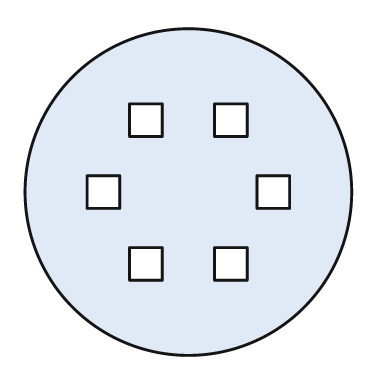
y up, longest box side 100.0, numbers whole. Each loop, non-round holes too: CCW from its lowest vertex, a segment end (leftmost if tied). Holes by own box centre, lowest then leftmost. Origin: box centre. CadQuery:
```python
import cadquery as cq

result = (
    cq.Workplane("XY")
    .moveTo(0.0, 0.0)
    .circle(50.0)
    .moveTo(-18.0, -27.0)
    .lineTo(-8.0, -27.0)
    .lineTo(-8.0, -17.0)
    .lineTo(-18.0, -17.0)
    .close()
    .moveTo(8.0, -27.0)
    .lineTo(18.0, -27.0)
    .lineTo(18.0, -17.0)
    .lineTo(8.0, -17.0)
    .close()
    .moveTo(-31.0, -5.0)
    .lineTo(-21.0, -5.0)
    .lineTo(-21.0, 5.0)
    .lineTo(-31.0, 5.0)
    .close()
    .moveTo(21.0, -5.0)
    .lineTo(31.0, -5.0)
    .lineTo(31.0, 5.0)
    .lineTo(21.0, 5.0)
    .close()
    .moveTo(-18.0, 17.0)
    .lineTo(-8.0, 17.0)
    .lineTo(-8.0, 27.0)
    .lineTo(-18.0, 27.0)
    .close()
    .moveTo(8.0, 17.0)
    .lineTo(18.0, 17.0)
    .lineTo(18.0, 27.0)
    .lineTo(8.0, 27.0)
    .close()
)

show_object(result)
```